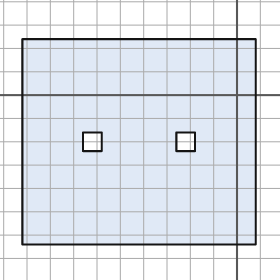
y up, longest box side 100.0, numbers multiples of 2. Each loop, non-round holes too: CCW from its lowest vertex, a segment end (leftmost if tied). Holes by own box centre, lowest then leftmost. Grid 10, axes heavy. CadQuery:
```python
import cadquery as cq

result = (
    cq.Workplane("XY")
    .moveTo(-92.0, -64.0)
    .lineTo(8.0, -64.0)
    .lineTo(8.0, 24.0)
    .lineTo(-92.0, 24.0)
    .close()
    .moveTo(-66.0, -24.0)
    .lineTo(-58.0, -24.0)
    .lineTo(-58.0, -16.0)
    .lineTo(-66.0, -16.0)
    .close()
    .moveTo(-26.0, -24.0)
    .lineTo(-18.0, -24.0)
    .lineTo(-18.0, -16.0)
    .lineTo(-26.0, -16.0)
    .close()
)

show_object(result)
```